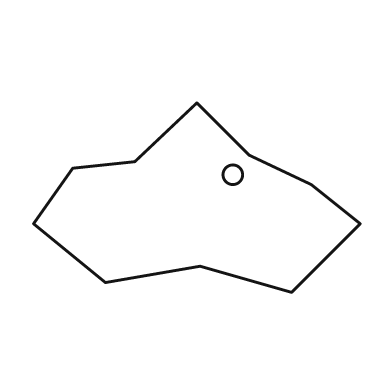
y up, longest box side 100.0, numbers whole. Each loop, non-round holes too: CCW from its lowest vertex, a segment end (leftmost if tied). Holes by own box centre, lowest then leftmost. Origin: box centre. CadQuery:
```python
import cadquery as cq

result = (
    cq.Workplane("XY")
    .moveTo(29.0, -29.0)
    .lineTo(50.0, -8.0)
    .lineTo(35.0, 4.0)
    .lineTo(16.0, 13.0)
    .lineTo(0.0, 29.0)
    .lineTo(-19.0, 11.0)
    .lineTo(-38.0, 9.0)
    .lineTo(-50.0, -8.0)
    .lineTo(-28.0, -26.0)
    .lineTo(1.0, -21.0)
    .close()
    .moveTo(11.0, 7.0)
    .circle(3.0)
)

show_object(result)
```